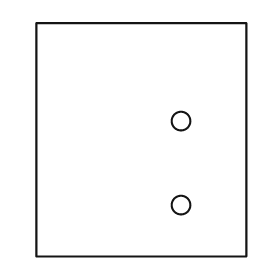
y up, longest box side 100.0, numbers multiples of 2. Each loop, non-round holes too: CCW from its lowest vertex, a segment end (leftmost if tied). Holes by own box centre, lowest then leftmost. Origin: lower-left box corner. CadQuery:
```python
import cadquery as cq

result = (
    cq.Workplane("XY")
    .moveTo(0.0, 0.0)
    .lineTo(90.0, 0.0)
    .lineTo(90.0, 100.0)
    .lineTo(0.0, 100.0)
    .close()
    .moveTo(62.0, 22.0)
    .circle(4.0)
    .moveTo(62.0, 58.0)
    .circle(4.0)
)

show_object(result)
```